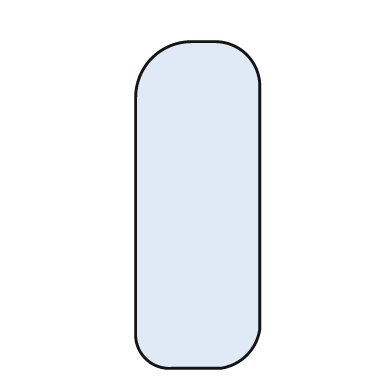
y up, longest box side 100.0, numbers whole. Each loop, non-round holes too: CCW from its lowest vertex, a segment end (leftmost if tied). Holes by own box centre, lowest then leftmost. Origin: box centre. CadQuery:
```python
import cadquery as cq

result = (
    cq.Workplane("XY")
    .moveTo(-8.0, -50.0)
    .lineTo(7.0, -50.0)
    .threePointArc((15.0, -46.0), (19.0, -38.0))
    .lineTo(19.0, 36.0)
    .threePointArc((15.0, 46.0), (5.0, 50.0))
    .lineTo(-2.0, 50.0)
    .threePointArc((-14.0, 45.0), (-19.0, 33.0))
    .lineTo(-19.0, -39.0)
    .threePointArc((-16.0, -47.0), (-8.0, -50.0))
    .close()
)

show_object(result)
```